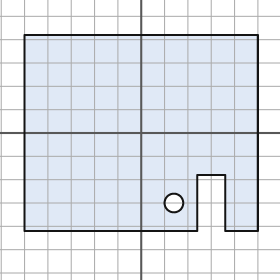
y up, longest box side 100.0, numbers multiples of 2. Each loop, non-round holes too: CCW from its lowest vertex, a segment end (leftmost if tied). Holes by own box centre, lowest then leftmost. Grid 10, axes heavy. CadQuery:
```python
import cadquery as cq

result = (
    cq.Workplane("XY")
    .moveTo(-50.0, -42.0)
    .lineTo(24.0, -42.0)
    .lineTo(24.0, -18.0)
    .lineTo(36.0, -18.0)
    .lineTo(36.0, -42.0)
    .lineTo(50.0, -42.0)
    .lineTo(50.0, 42.0)
    .lineTo(-50.0, 42.0)
    .close()
    .moveTo(14.0, -30.0)
    .circle(4.0)
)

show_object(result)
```